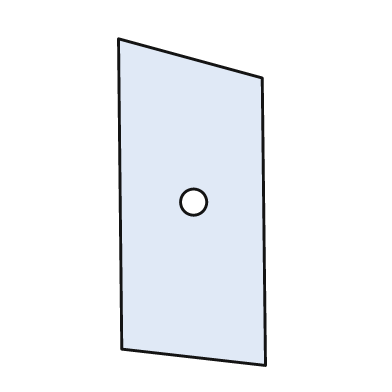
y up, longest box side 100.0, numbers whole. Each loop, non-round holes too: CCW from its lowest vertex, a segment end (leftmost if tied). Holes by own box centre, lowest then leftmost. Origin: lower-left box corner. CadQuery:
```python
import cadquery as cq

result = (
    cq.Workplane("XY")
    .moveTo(45.0, 0.0)
    .lineTo(44.0, 88.0)
    .lineTo(0.0, 100.0)
    .lineTo(1.0, 5.0)
    .close()
    .moveTo(23.0, 50.0)
    .circle(4.0)
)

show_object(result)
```